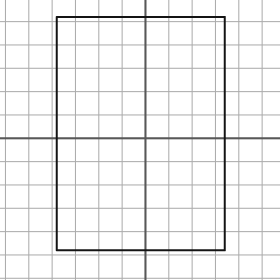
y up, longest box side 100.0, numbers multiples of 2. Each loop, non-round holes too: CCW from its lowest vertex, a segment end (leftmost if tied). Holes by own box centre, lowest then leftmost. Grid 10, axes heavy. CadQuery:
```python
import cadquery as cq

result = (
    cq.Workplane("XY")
    .moveTo(-38.0, -48.0)
    .lineTo(34.0, -48.0)
    .lineTo(34.0, 52.0)
    .lineTo(-38.0, 52.0)
    .close()
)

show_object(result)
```